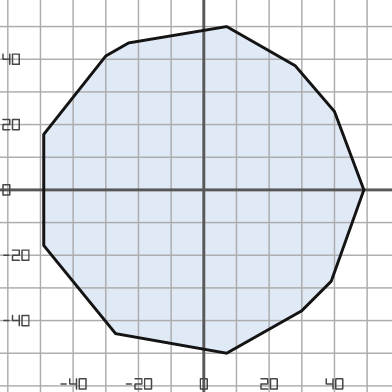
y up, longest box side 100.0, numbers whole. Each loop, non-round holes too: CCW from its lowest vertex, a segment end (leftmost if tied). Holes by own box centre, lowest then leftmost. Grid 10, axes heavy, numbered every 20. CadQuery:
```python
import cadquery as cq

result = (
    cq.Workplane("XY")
    .moveTo(7.0, -50.0)
    .lineTo(30.0, -37.0)
    .lineTo(39.0, -28.0)
    .lineTo(49.0, 0.0)
    .lineTo(40.0, 24.0)
    .lineTo(28.0, 38.0)
    .lineTo(7.0, 50.0)
    .lineTo(-23.0, 45.0)
    .lineTo(-30.0, 41.0)
    .lineTo(-49.0, 17.0)
    .lineTo(-49.0, -17.0)
    .lineTo(-27.0, -44.0)
    .close()
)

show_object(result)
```